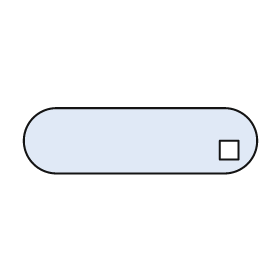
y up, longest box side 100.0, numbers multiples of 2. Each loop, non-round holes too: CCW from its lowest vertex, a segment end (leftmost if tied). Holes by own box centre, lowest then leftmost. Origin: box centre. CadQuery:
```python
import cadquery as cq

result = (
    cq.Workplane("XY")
    .moveTo(-36.0, -14.0)
    .lineTo(36.0, -14.0)
    .threePointArc((50.0, 0.0), (36.0, 14.0))
    .lineTo(-36.0, 14.0)
    .threePointArc((-50.0, 0.0), (-36.0, -14.0))
    .close()
    .moveTo(34.0, -8.0)
    .lineTo(42.0, -8.0)
    .lineTo(42.0, 0.0)
    .lineTo(34.0, 0.0)
    .close()
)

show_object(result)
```